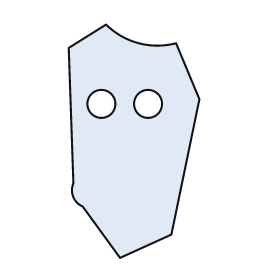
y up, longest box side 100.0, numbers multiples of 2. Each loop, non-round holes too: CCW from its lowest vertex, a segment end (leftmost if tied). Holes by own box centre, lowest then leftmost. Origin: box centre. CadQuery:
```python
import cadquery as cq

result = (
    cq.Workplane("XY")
    .moveTo(-6.0, -50.0)
    .lineTo(16.0, -40.0)
    .lineTo(28.0, 18.0)
    .lineTo(18.0, 42.0)
    .threePointArc((2.0, 42.0), (-12.0, 50.0))
    .lineTo(-28.0, 40.0)
    .lineTo(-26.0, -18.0)
    .threePointArc((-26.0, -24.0), (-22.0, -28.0))
    .close()
    .moveTo(-14.0, 16.0)
    .circle(6.0)
    .moveTo(6.0, 16.0)
    .circle(6.0)
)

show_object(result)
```